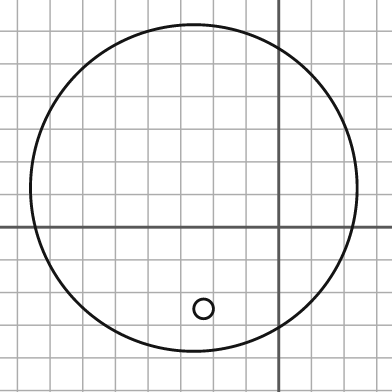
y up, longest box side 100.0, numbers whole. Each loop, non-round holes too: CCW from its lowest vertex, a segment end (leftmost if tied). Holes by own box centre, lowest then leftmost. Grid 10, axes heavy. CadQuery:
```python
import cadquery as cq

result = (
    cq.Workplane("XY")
    .moveTo(-26.0, 12.0)
    .circle(50.0)
    .moveTo(-23.0, -25.0)
    .circle(3.0)
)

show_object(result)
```